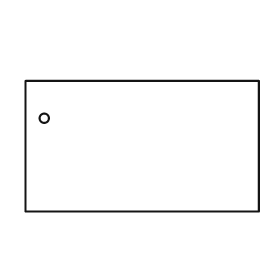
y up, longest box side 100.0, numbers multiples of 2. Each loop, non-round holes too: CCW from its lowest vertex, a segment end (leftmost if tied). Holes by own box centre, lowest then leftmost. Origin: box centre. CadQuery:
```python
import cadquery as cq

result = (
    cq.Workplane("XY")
    .moveTo(-50.0, -28.0)
    .lineTo(50.0, -28.0)
    .lineTo(50.0, 28.0)
    .lineTo(-50.0, 28.0)
    .close()
    .moveTo(-42.0, 12.0)
    .circle(2.0)
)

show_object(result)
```